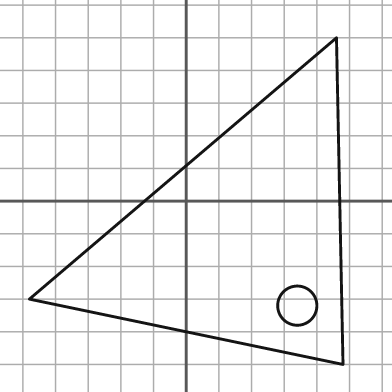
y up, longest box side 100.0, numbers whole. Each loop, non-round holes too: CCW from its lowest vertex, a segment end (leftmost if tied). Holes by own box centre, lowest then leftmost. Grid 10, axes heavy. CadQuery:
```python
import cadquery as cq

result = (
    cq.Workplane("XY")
    .moveTo(48.0, -50.0)
    .lineTo(46.0, 50.0)
    .lineTo(-48.0, -30.0)
    .close()
    .moveTo(34.0, -32.0)
    .circle(6.0)
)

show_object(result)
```